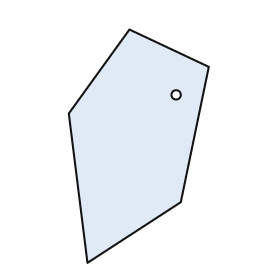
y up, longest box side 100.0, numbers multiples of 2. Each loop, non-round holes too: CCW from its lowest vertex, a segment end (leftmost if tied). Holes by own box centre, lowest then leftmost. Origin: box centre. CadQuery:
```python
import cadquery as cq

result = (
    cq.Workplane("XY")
    .moveTo(-22.0, -50.0)
    .lineTo(18.0, -24.0)
    .lineTo(30.0, 34.0)
    .lineTo(-4.0, 50.0)
    .lineTo(-30.0, 14.0)
    .close()
    .moveTo(16.0, 22.0)
    .circle(2.0)
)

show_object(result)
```